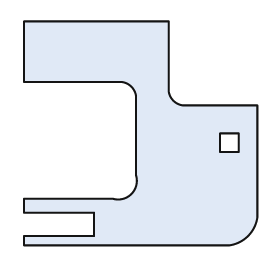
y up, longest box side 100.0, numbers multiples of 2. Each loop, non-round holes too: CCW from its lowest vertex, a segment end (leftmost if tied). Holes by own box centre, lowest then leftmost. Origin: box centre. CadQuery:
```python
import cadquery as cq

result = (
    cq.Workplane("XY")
    .moveTo(-50.0, -48.0)
    .lineTo(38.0, -48.0)
    .threePointArc((46.0, -44.0), (50.0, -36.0))
    .lineTo(50.0, 12.0)
    .lineTo(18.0, 12.0)
    .threePointArc((14.0, 14.0), (12.0, 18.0))
    .lineTo(12.0, 48.0)
    .lineTo(-50.0, 48.0)
    .lineTo(-50.0, 22.0)
    .lineTo(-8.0, 22.0)
    .threePointArc((-4.0, 20.0), (-2.0, 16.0))
    .lineTo(-2.0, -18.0)
    .threePointArc((-4.0, -26.0), (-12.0, -28.0))
    .lineTo(-50.0, -28.0)
    .lineTo(-50.0, -34.0)
    .lineTo(-20.0, -34.0)
    .lineTo(-20.0, -44.0)
    .lineTo(-50.0, -44.0)
    .close()
    .moveTo(34.0, -8.0)
    .lineTo(42.0, -8.0)
    .lineTo(42.0, 0.0)
    .lineTo(34.0, 0.0)
    .close()
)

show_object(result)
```